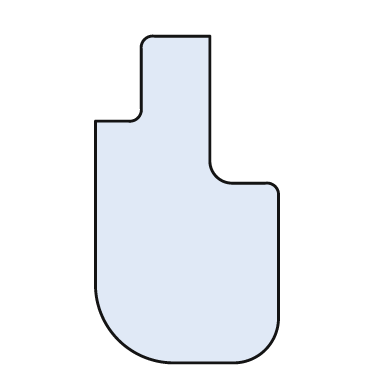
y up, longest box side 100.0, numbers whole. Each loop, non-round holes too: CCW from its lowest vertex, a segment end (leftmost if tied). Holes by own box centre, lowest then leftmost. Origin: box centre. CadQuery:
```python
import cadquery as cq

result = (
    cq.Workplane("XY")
    .moveTo(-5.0, -50.0)
    .lineTo(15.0, -50.0)
    .threePointArc((24.0, -46.0), (28.0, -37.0))
    .lineTo(28.0, 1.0)
    .threePointArc((27.0, 4.0), (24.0, 5.0))
    .lineTo(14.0, 5.0)
    .threePointArc((9.0, 7.0), (7.0, 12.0))
    .lineTo(7.0, 50.0)
    .lineTo(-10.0, 50.0)
    .threePointArc((-13.0, 49.0), (-14.0, 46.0))
    .lineTo(-14.0, 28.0)
    .threePointArc((-15.0, 25.0), (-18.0, 24.0))
    .lineTo(-28.0, 24.0)
    .lineTo(-28.0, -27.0)
    .threePointArc((-21.0, -43.0), (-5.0, -50.0))
    .close()
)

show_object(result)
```